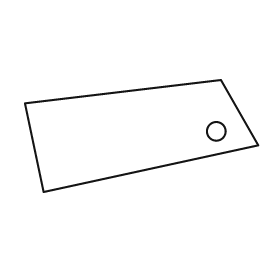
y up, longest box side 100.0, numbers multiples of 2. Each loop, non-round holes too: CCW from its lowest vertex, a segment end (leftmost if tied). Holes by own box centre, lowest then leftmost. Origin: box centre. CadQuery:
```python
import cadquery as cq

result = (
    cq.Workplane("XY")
    .moveTo(-42.0, -24.0)
    .lineTo(50.0, -4.0)
    .lineTo(34.0, 24.0)
    .lineTo(-50.0, 14.0)
    .close()
    .moveTo(32.0, 2.0)
    .circle(4.0)
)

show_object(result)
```